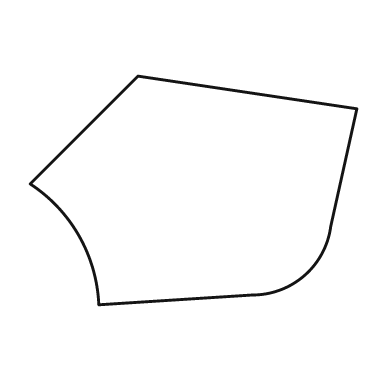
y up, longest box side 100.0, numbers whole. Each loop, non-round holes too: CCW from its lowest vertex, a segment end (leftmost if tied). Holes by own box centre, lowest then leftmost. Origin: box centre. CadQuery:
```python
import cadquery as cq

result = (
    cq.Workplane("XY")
    .moveTo(-29.0, -35.0)
    .lineTo(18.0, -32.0)
    .threePointArc((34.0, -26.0), (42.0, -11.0))
    .lineTo(50.0, 25.0)
    .lineTo(-17.0, 35.0)
    .lineTo(-50.0, 2.0)
    .threePointArc((-35.0, -14.0), (-29.0, -35.0))
    .close()
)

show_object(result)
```